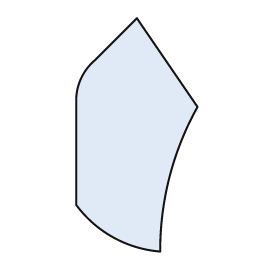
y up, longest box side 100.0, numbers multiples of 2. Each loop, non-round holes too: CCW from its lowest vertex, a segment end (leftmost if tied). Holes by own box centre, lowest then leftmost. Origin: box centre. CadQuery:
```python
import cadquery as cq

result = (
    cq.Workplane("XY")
    .moveTo(10.0, -50.0)
    .threePointArc((14.0, -18.0), (26.0, 12.0))
    .lineTo(0.0, 50.0)
    .lineTo(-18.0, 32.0)
    .threePointArc((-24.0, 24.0), (-26.0, 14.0))
    .lineTo(-26.0, -30.0)
    .threePointArc((-10.0, -44.0), (10.0, -50.0))
    .close()
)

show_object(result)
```